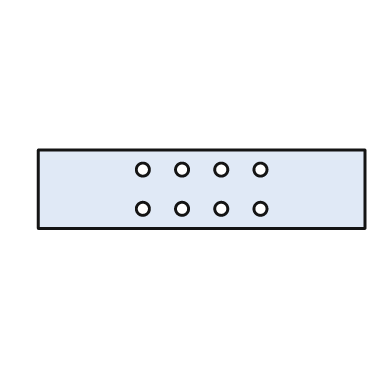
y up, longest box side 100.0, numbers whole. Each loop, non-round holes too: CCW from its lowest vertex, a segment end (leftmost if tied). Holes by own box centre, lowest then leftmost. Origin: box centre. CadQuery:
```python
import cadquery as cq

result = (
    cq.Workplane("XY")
    .moveTo(-50.0, -12.0)
    .lineTo(50.0, -12.0)
    .lineTo(50.0, 12.0)
    .lineTo(-50.0, 12.0)
    .close()
    .moveTo(-18.0, -6.0)
    .circle(2.0)
    .moveTo(-6.0, -6.0)
    .circle(2.0)
    .moveTo(6.0, -6.0)
    .circle(2.0)
    .moveTo(18.0, -6.0)
    .circle(2.0)
    .moveTo(-18.0, 6.0)
    .circle(2.0)
    .moveTo(-6.0, 6.0)
    .circle(2.0)
    .moveTo(6.0, 6.0)
    .circle(2.0)
    .moveTo(18.0, 6.0)
    .circle(2.0)
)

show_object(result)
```